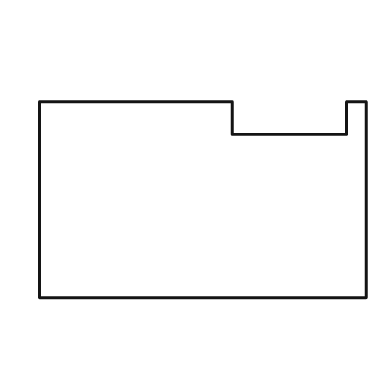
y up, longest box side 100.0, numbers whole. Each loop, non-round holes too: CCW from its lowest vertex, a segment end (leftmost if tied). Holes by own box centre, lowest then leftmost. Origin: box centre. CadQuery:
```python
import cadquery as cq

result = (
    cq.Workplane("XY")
    .moveTo(-50.0, -30.0)
    .lineTo(50.0, -30.0)
    .lineTo(50.0, 30.0)
    .lineTo(44.0, 30.0)
    .lineTo(44.0, 20.0)
    .lineTo(9.0, 20.0)
    .lineTo(9.0, 30.0)
    .lineTo(-50.0, 30.0)
    .close()
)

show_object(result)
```